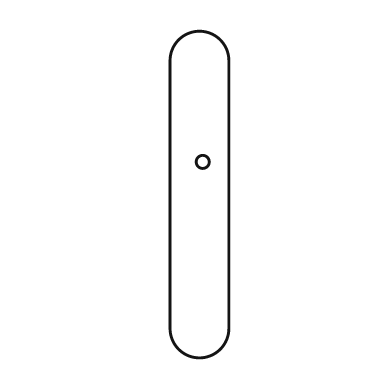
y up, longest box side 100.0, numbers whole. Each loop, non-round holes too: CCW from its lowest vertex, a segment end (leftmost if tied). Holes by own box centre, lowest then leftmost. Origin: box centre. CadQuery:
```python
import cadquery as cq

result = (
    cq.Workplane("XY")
    .moveTo(-9.0, -41.0)
    .threePointArc((0.0, -50.0), (9.0, -41.0))
    .lineTo(9.0, 41.0)
    .threePointArc((0.0, 50.0), (-9.0, 41.0))
    .close()
    .moveTo(1.0, 10.0)
    .circle(2.0)
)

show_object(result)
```